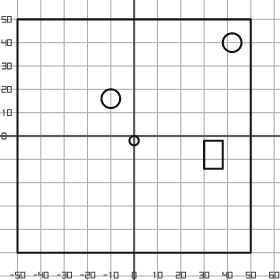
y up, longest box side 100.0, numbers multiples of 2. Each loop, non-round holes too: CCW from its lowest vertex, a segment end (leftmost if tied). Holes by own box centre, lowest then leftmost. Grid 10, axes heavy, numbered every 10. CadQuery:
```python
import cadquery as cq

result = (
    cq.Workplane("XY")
    .moveTo(-50.0, -50.0)
    .lineTo(50.0, -50.0)
    .lineTo(50.0, 50.0)
    .lineTo(-50.0, 50.0)
    .close()
    .moveTo(30.0, -14.0)
    .lineTo(38.0, -14.0)
    .lineTo(38.0, -2.0)
    .lineTo(30.0, -2.0)
    .close()
    .moveTo(0.0, -2.0)
    .circle(2.0)
    .moveTo(-10.0, 16.0)
    .circle(4.0)
    .moveTo(42.0, 40.0)
    .circle(4.0)
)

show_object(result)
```